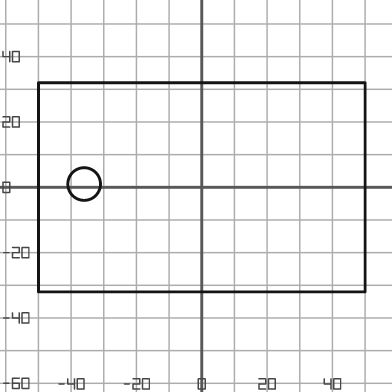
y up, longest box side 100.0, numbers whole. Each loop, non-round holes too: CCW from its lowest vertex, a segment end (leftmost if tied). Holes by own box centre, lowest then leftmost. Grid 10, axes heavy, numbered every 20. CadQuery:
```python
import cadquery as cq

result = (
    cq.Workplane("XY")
    .moveTo(-50.0, -32.0)
    .lineTo(50.0, -32.0)
    .lineTo(50.0, 32.0)
    .lineTo(-50.0, 32.0)
    .close()
    .moveTo(-36.0, 1.0)
    .circle(5.0)
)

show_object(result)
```